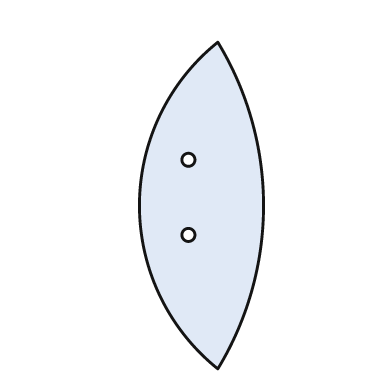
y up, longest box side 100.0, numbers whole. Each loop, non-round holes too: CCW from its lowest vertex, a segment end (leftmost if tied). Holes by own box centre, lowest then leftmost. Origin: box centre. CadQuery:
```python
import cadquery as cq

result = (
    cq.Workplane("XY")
    .moveTo(5.0, -50.0)
    .threePointArc((19.0, 0.0), (5.0, 50.0))
    .threePointArc((-19.0, 0.0), (5.0, -50.0))
    .close()
    .moveTo(-4.0, -9.0)
    .circle(2.0)
    .moveTo(-4.0, 14.0)
    .circle(2.0)
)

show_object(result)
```